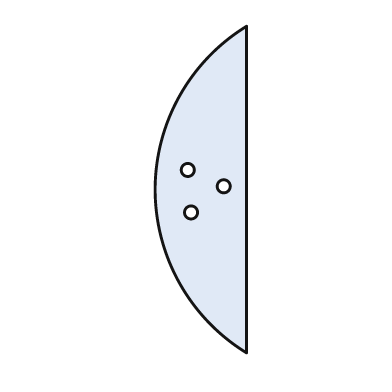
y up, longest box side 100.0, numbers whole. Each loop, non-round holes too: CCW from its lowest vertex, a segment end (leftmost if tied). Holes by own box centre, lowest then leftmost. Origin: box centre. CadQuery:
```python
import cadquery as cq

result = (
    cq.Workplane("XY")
    .moveTo(14.0, -50.0)
    .lineTo(14.0, 50.0)
    .threePointArc((-14.0, 0.0), (14.0, -50.0))
    .close()
    .moveTo(-3.0, -7.0)
    .circle(2.0)
    .moveTo(7.0, 1.0)
    .circle(2.0)
    .moveTo(-4.0, 6.0)
    .circle(2.0)
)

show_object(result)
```